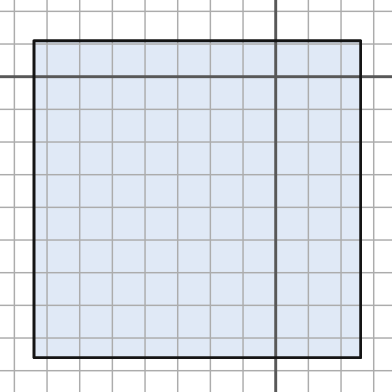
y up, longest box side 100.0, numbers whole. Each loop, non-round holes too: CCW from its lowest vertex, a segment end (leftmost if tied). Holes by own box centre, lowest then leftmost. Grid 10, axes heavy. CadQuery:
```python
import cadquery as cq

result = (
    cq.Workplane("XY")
    .moveTo(-74.0, -86.0)
    .lineTo(26.0, -86.0)
    .lineTo(26.0, 11.0)
    .lineTo(-74.0, 11.0)
    .close()
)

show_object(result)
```